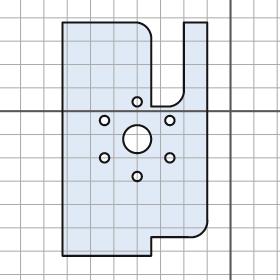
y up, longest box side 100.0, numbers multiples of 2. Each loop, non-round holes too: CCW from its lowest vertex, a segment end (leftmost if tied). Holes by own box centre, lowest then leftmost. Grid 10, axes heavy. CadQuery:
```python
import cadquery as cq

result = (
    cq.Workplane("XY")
    .moveTo(-72.0, -62.0)
    .lineTo(-34.0, -62.0)
    .lineTo(-34.0, -54.0)
    .lineTo(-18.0, -54.0)
    .threePointArc((-12.0, -52.0), (-10.0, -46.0))
    .lineTo(-10.0, 38.0)
    .lineTo(-20.0, 38.0)
    .lineTo(-20.0, 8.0)
    .threePointArc((-22.0, 4.0), (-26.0, 2.0))
    .lineTo(-34.0, 2.0)
    .lineTo(-34.0, 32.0)
    .threePointArc((-36.0, 36.0), (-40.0, 38.0))
    .lineTo(-72.0, 38.0)
    .close()
    .moveTo(-40.0, -28.0)
    .circle(2.0)
    .moveTo(-54.0, -20.0)
    .circle(2.0)
    .moveTo(-26.0, -20.0)
    .circle(2.0)
    .moveTo(-40.0, -12.0)
    .circle(6.0)
    .moveTo(-54.0, -4.0)
    .circle(2.0)
    .moveTo(-26.0, -4.0)
    .circle(2.0)
    .moveTo(-40.0, 4.0)
    .circle(2.0)
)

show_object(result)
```